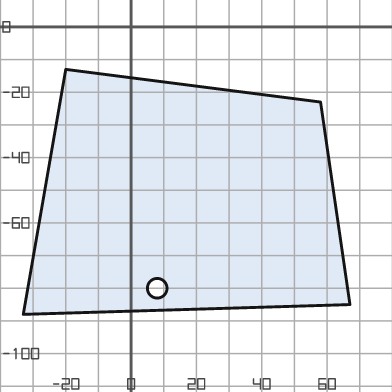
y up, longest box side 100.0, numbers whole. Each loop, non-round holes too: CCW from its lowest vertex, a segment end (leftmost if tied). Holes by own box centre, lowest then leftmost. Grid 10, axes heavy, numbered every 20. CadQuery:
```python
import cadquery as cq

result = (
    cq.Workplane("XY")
    .moveTo(-33.0, -88.0)
    .lineTo(67.0, -85.0)
    .lineTo(58.0, -23.0)
    .lineTo(-20.0, -13.0)
    .close()
    .moveTo(8.0, -80.0)
    .circle(3.0)
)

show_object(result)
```